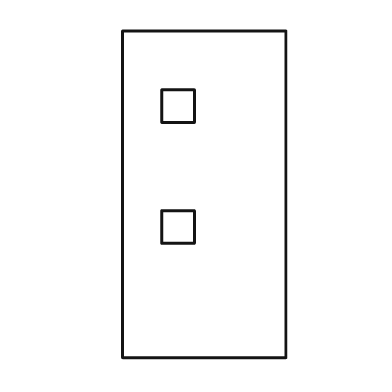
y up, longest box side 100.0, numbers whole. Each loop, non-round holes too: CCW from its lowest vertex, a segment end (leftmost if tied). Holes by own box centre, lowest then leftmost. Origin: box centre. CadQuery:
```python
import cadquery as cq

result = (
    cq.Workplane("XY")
    .moveTo(-25.0, -50.0)
    .lineTo(25.0, -50.0)
    .lineTo(25.0, 50.0)
    .lineTo(-25.0, 50.0)
    .close()
    .moveTo(-13.0, -15.0)
    .lineTo(-3.0, -15.0)
    .lineTo(-3.0, -5.0)
    .lineTo(-13.0, -5.0)
    .close()
    .moveTo(-13.0, 22.0)
    .lineTo(-3.0, 22.0)
    .lineTo(-3.0, 32.0)
    .lineTo(-13.0, 32.0)
    .close()
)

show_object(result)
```